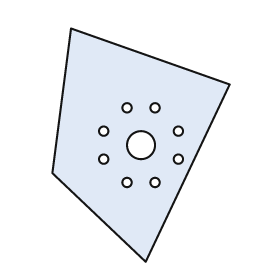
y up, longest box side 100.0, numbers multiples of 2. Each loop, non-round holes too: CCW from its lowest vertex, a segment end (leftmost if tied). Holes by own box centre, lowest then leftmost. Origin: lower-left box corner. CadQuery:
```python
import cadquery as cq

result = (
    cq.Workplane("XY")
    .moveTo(40.0, 0.0)
    .lineTo(76.0, 76.0)
    .lineTo(8.0, 100.0)
    .lineTo(0.0, 38.0)
    .close()
    .moveTo(32.0, 34.0)
    .circle(2.0)
    .moveTo(44.0, 34.0)
    .circle(2.0)
    .moveTo(22.0, 44.0)
    .circle(2.0)
    .moveTo(54.0, 44.0)
    .circle(2.0)
    .moveTo(38.0, 50.0)
    .circle(6.0)
    .moveTo(22.0, 56.0)
    .circle(2.0)
    .moveTo(54.0, 56.0)
    .circle(2.0)
    .moveTo(32.0, 66.0)
    .circle(2.0)
    .moveTo(44.0, 66.0)
    .circle(2.0)
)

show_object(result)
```